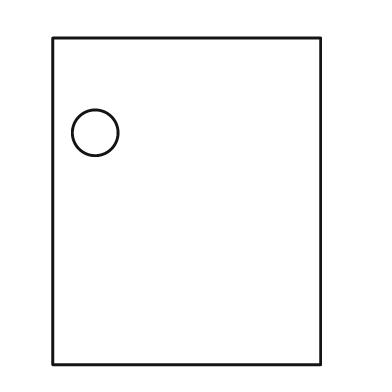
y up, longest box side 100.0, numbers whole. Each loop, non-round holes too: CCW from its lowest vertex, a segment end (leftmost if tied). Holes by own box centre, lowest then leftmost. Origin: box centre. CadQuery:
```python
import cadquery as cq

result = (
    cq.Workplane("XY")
    .moveTo(-41.0, -50.0)
    .lineTo(41.0, -50.0)
    .lineTo(41.0, 50.0)
    .lineTo(-41.0, 50.0)
    .close()
    .moveTo(-28.0, 21.0)
    .circle(7.0)
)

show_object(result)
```